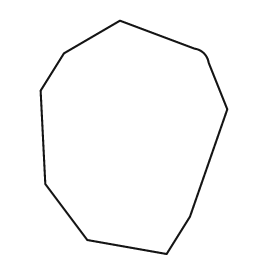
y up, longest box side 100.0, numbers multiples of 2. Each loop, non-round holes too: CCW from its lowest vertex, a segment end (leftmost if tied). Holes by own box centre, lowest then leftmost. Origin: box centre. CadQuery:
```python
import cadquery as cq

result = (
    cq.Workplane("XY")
    .moveTo(14.0, -50.0)
    .lineTo(24.0, -34.0)
    .lineTo(40.0, 12.0)
    .lineTo(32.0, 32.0)
    .threePointArc((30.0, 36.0), (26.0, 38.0))
    .lineTo(-6.0, 50.0)
    .lineTo(-30.0, 36.0)
    .lineTo(-40.0, 20.0)
    .lineTo(-38.0, -20.0)
    .lineTo(-20.0, -44.0)
    .close()
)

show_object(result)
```